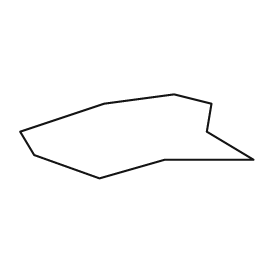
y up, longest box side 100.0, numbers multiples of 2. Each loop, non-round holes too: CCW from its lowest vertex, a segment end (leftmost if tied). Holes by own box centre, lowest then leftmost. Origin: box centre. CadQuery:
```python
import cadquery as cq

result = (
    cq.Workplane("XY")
    .moveTo(-16.0, -18.0)
    .lineTo(12.0, -10.0)
    .lineTo(50.0, -10.0)
    .lineTo(30.0, 2.0)
    .lineTo(32.0, 14.0)
    .lineTo(16.0, 18.0)
    .lineTo(-14.0, 14.0)
    .lineTo(-50.0, 2.0)
    .lineTo(-44.0, -8.0)
    .close()
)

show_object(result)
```